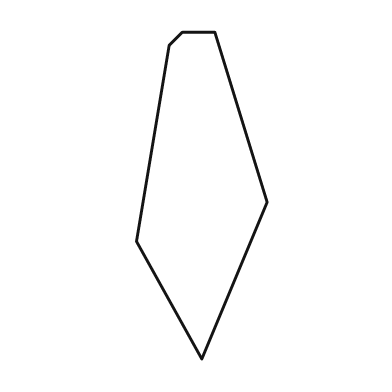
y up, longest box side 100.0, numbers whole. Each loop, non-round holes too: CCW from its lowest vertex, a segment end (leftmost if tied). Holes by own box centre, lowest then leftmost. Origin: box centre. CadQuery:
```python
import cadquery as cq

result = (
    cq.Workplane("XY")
    .moveTo(0.0, -50.0)
    .lineTo(20.0, -2.0)
    .lineTo(4.0, 50.0)
    .lineTo(-6.0, 50.0)
    .lineTo(-10.0, 46.0)
    .lineTo(-20.0, -14.0)
    .close()
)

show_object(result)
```